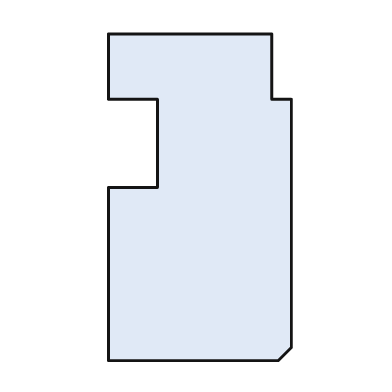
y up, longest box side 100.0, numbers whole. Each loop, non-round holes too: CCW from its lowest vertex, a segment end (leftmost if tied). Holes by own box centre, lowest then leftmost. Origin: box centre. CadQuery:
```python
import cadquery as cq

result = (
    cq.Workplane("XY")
    .moveTo(-28.0, -50.0)
    .lineTo(24.0, -50.0)
    .lineTo(28.0, -46.0)
    .lineTo(28.0, 30.0)
    .lineTo(22.0, 30.0)
    .lineTo(22.0, 50.0)
    .lineTo(-28.0, 50.0)
    .lineTo(-28.0, 30.0)
    .lineTo(-13.0, 30.0)
    .lineTo(-13.0, 3.0)
    .lineTo(-28.0, 3.0)
    .close()
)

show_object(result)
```